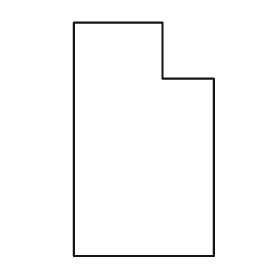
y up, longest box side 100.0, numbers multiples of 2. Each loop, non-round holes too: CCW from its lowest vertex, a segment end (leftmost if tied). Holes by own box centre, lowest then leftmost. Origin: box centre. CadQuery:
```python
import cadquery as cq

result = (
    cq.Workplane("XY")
    .moveTo(-30.0, -50.0)
    .lineTo(30.0, -50.0)
    .lineTo(30.0, 26.0)
    .lineTo(8.0, 26.0)
    .lineTo(8.0, 50.0)
    .lineTo(-30.0, 50.0)
    .close()
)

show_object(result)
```